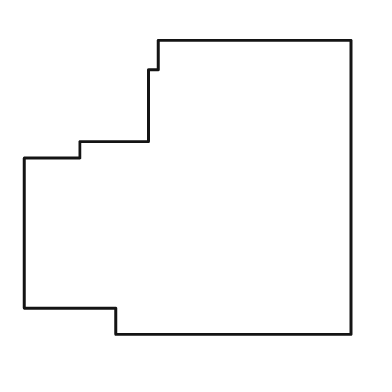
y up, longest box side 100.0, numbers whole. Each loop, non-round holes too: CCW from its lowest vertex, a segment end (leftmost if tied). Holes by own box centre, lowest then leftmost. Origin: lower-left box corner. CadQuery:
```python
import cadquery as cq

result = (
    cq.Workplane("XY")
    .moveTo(28.0, 0.0)
    .lineTo(100.0, 0.0)
    .lineTo(100.0, 90.0)
    .lineTo(41.0, 90.0)
    .lineTo(41.0, 81.0)
    .lineTo(38.0, 81.0)
    .lineTo(38.0, 59.0)
    .lineTo(17.0, 59.0)
    .lineTo(17.0, 54.0)
    .lineTo(0.0, 54.0)
    .lineTo(0.0, 8.0)
    .lineTo(28.0, 8.0)
    .close()
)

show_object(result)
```